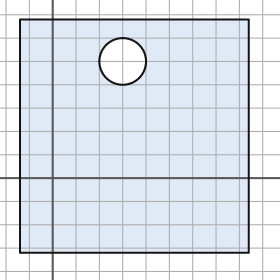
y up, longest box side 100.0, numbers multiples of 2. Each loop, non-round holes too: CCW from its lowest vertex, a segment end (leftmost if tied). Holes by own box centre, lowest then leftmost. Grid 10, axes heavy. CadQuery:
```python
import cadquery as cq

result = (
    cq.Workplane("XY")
    .moveTo(-14.0, -32.0)
    .lineTo(84.0, -32.0)
    .lineTo(84.0, 68.0)
    .lineTo(-14.0, 68.0)
    .close()
    .moveTo(30.0, 50.0)
    .circle(10.0)
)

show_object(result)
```